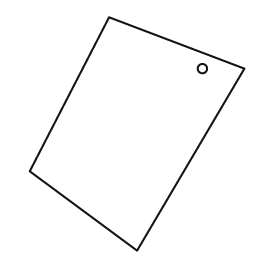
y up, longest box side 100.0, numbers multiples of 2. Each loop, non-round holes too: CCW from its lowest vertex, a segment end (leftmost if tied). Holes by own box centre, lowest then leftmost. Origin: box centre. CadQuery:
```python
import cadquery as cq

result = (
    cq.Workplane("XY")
    .moveTo(0.0, -50.0)
    .lineTo(46.0, 28.0)
    .lineTo(-12.0, 50.0)
    .lineTo(-46.0, -16.0)
    .close()
    .moveTo(28.0, 28.0)
    .circle(2.0)
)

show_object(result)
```